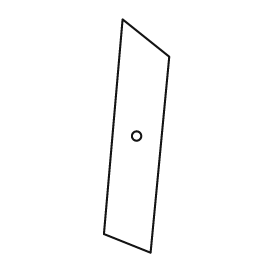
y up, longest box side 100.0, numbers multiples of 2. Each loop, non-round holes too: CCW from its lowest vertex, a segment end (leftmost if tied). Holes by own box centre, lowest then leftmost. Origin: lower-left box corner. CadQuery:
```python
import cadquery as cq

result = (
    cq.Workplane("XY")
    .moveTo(20.0, 0.0)
    .lineTo(28.0, 84.0)
    .lineTo(8.0, 100.0)
    .lineTo(0.0, 8.0)
    .close()
    .moveTo(14.0, 50.0)
    .circle(2.0)
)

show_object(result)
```